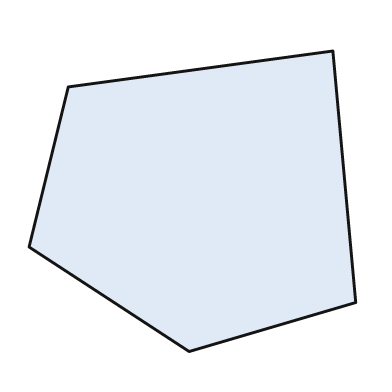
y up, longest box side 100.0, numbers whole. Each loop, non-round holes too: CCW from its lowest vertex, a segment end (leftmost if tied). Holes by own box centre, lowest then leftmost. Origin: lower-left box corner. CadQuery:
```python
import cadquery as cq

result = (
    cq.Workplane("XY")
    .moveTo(49.0, 0.0)
    .lineTo(100.0, 15.0)
    .lineTo(93.0, 92.0)
    .lineTo(12.0, 81.0)
    .lineTo(0.0, 32.0)
    .close()
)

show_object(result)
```